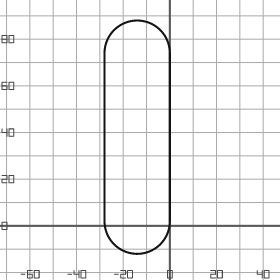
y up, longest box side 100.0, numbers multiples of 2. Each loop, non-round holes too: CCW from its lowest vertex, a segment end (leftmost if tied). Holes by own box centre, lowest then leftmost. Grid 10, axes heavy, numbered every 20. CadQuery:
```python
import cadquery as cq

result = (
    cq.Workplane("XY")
    .moveTo(-28.0, 2.0)
    .threePointArc((-14.0, -12.0), (0.0, 2.0))
    .lineTo(0.0, 74.0)
    .threePointArc((-14.0, 88.0), (-28.0, 74.0))
    .close()
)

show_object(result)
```